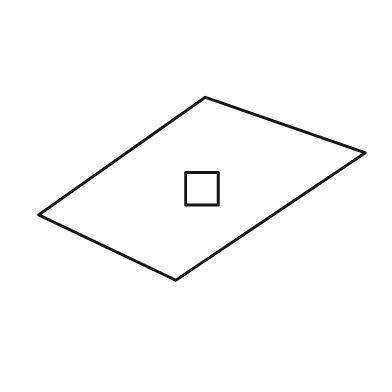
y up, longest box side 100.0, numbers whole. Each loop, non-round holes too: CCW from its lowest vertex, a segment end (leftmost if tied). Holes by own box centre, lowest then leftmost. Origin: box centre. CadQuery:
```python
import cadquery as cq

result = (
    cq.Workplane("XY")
    .moveTo(-8.0, -28.0)
    .lineTo(50.0, 11.0)
    .lineTo(1.0, 28.0)
    .lineTo(-50.0, -8.0)
    .close()
    .moveTo(-5.0, -5.0)
    .lineTo(5.0, -5.0)
    .lineTo(5.0, 5.0)
    .lineTo(-5.0, 5.0)
    .close()
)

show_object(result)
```